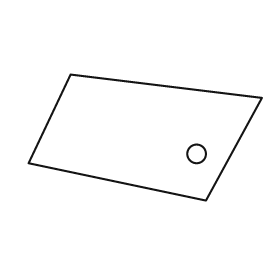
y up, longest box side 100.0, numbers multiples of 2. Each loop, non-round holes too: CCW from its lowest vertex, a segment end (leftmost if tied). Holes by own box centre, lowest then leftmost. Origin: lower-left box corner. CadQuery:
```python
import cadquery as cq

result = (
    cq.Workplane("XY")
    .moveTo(76.0, 0.0)
    .lineTo(100.0, 44.0)
    .lineTo(18.0, 54.0)
    .lineTo(0.0, 16.0)
    .close()
    .moveTo(72.0, 20.0)
    .circle(4.0)
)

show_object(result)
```